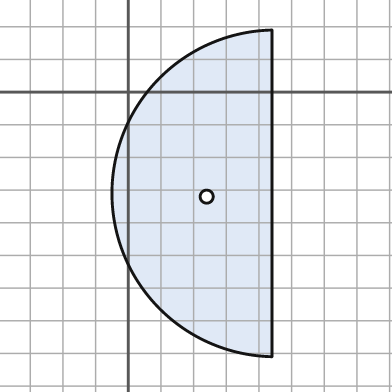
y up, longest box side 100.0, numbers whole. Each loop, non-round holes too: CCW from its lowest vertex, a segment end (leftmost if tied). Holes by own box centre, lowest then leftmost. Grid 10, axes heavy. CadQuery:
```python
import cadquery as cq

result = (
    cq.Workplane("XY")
    .moveTo(44.0, -81.0)
    .lineTo(44.0, 19.0)
    .threePointArc((-5.0, -31.0), (44.0, -81.0))
    .close()
    .moveTo(24.0, -32.0)
    .circle(2.0)
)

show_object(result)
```